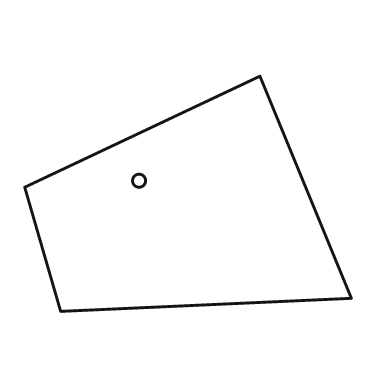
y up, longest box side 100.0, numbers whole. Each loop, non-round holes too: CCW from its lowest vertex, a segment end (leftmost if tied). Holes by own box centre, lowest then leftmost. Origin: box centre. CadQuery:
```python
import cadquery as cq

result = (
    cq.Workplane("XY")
    .moveTo(-39.0, -36.0)
    .lineTo(50.0, -32.0)
    .lineTo(22.0, 36.0)
    .lineTo(-50.0, 2.0)
    .close()
    .moveTo(-15.0, 4.0)
    .circle(2.0)
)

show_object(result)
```